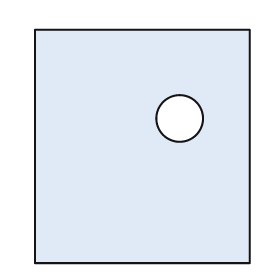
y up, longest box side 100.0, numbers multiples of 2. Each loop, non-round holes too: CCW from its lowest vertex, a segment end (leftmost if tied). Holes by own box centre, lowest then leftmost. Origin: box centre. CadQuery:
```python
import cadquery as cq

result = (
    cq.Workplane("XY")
    .moveTo(-46.0, -50.0)
    .lineTo(46.0, -50.0)
    .lineTo(46.0, 50.0)
    .lineTo(-46.0, 50.0)
    .close()
    .moveTo(16.0, 12.0)
    .circle(10.0)
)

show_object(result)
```